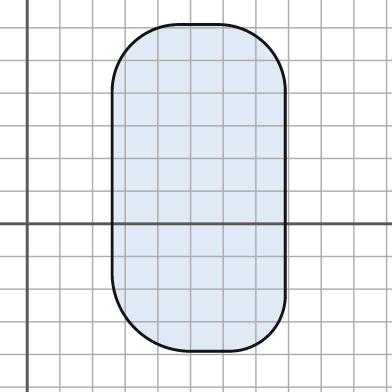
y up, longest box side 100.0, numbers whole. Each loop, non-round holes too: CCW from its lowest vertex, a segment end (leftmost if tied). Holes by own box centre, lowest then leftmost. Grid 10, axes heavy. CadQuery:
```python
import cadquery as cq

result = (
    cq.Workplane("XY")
    .moveTo(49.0, -39.0)
    .lineTo(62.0, -39.0)
    .threePointArc((74.0, -34.0), (79.0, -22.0))
    .lineTo(79.0, 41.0)
    .threePointArc((73.0, 55.0), (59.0, 61.0))
    .lineTo(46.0, 61.0)
    .threePointArc((32.0, 55.0), (26.0, 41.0))
    .lineTo(26.0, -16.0)
    .threePointArc((33.0, -32.0), (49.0, -39.0))
    .close()
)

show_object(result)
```